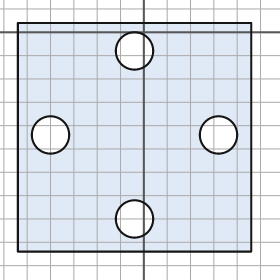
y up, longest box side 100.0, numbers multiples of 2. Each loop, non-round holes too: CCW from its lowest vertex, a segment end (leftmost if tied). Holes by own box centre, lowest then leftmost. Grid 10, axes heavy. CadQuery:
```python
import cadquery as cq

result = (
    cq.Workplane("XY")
    .moveTo(-54.0, -94.0)
    .lineTo(46.0, -94.0)
    .lineTo(46.0, 4.0)
    .lineTo(-54.0, 4.0)
    .close()
    .moveTo(-4.0, -80.0)
    .circle(8.0)
    .moveTo(-40.0, -44.0)
    .circle(8.0)
    .moveTo(32.0, -44.0)
    .circle(8.0)
    .moveTo(-4.0, -8.0)
    .circle(8.0)
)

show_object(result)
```